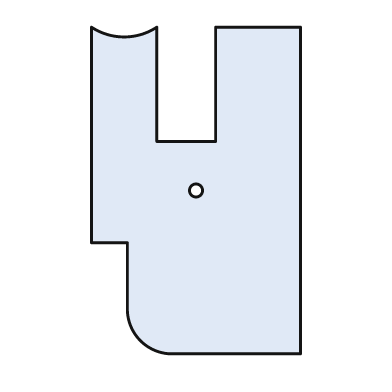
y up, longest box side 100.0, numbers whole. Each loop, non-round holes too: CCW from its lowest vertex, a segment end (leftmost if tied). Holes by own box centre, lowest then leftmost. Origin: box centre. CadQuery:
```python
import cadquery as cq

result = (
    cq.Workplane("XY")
    .moveTo(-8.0, -50.0)
    .lineTo(32.0, -50.0)
    .lineTo(32.0, 50.0)
    .lineTo(6.0, 50.0)
    .lineTo(6.0, 15.0)
    .lineTo(-12.0, 15.0)
    .lineTo(-12.0, 50.0)
    .threePointArc((-22.0, 47.0), (-32.0, 50.0))
    .lineTo(-32.0, -16.0)
    .lineTo(-21.0, -16.0)
    .lineTo(-21.0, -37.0)
    .threePointArc((-17.0, -46.0), (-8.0, -50.0))
    .close()
    .moveTo(0.0, 0.0)
    .circle(2.0)
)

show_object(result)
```